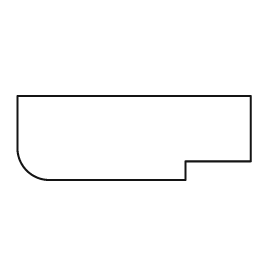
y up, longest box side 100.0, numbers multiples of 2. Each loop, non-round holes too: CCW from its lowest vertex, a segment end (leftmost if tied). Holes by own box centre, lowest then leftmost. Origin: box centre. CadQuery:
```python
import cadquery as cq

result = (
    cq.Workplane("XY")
    .moveTo(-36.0, -18.0)
    .lineTo(22.0, -18.0)
    .lineTo(22.0, -10.0)
    .lineTo(50.0, -10.0)
    .lineTo(50.0, 18.0)
    .lineTo(-50.0, 18.0)
    .lineTo(-50.0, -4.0)
    .threePointArc((-46.0, -14.0), (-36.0, -18.0))
    .close()
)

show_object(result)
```